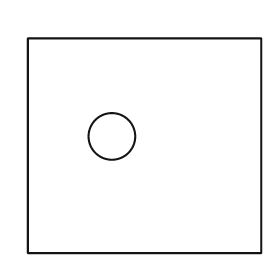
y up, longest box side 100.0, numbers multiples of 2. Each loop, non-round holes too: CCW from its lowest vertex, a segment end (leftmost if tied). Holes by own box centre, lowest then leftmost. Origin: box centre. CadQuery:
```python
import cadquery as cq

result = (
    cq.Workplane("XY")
    .moveTo(-50.0, -46.0)
    .lineTo(50.0, -46.0)
    .lineTo(50.0, 46.0)
    .lineTo(-50.0, 46.0)
    .close()
    .moveTo(-14.0, 4.0)
    .circle(10.0)
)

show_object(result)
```